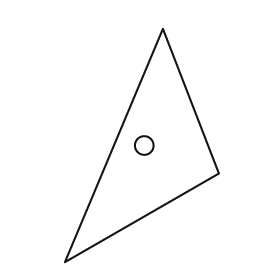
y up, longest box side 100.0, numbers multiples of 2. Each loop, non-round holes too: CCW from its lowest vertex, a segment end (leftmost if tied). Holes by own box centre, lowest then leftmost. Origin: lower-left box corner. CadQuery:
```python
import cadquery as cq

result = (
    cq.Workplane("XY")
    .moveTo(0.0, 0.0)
    .lineTo(66.0, 38.0)
    .lineTo(42.0, 100.0)
    .close()
    .moveTo(34.0, 50.0)
    .circle(4.0)
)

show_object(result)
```